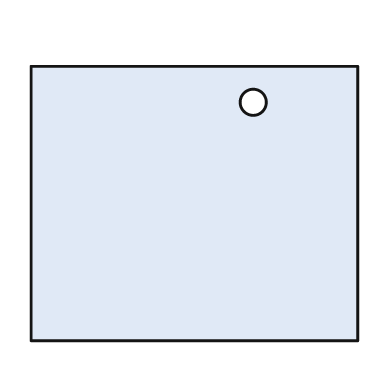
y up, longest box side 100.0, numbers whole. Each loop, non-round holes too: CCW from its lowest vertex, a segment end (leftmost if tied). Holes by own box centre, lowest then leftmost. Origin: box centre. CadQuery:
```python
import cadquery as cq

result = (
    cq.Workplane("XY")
    .moveTo(-50.0, -42.0)
    .lineTo(50.0, -42.0)
    .lineTo(50.0, 42.0)
    .lineTo(-50.0, 42.0)
    .close()
    .moveTo(18.0, 31.0)
    .circle(4.0)
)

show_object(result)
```